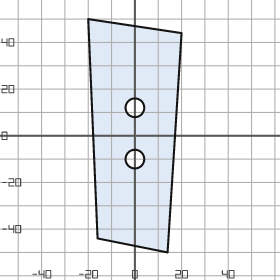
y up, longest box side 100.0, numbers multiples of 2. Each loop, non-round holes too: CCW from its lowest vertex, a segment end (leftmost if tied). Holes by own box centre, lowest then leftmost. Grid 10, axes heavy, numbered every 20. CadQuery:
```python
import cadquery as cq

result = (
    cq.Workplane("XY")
    .moveTo(14.0, -50.0)
    .lineTo(20.0, 44.0)
    .lineTo(-20.0, 50.0)
    .lineTo(-16.0, -44.0)
    .close()
    .moveTo(0.0, -10.0)
    .circle(4.0)
    .moveTo(0.0, 12.0)
    .circle(4.0)
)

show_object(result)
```